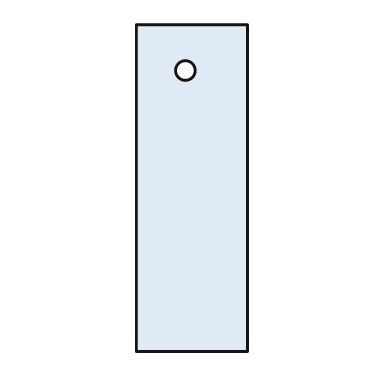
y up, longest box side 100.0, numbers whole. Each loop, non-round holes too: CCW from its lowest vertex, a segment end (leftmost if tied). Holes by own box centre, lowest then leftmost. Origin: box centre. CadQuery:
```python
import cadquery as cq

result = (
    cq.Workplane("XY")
    .moveTo(-17.0, -50.0)
    .lineTo(17.0, -50.0)
    .lineTo(17.0, 50.0)
    .lineTo(-17.0, 50.0)
    .close()
    .moveTo(-2.0, 36.0)
    .circle(3.0)
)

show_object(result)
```